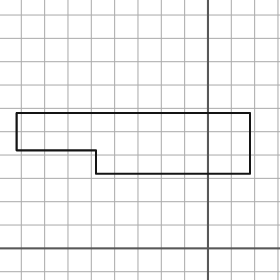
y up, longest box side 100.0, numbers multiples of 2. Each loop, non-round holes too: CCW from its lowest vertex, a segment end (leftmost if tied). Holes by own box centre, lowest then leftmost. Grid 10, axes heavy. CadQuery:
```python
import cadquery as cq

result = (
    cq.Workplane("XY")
    .moveTo(-48.0, 32.0)
    .lineTo(18.0, 32.0)
    .lineTo(18.0, 58.0)
    .lineTo(-82.0, 58.0)
    .lineTo(-82.0, 42.0)
    .lineTo(-48.0, 42.0)
    .close()
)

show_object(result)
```